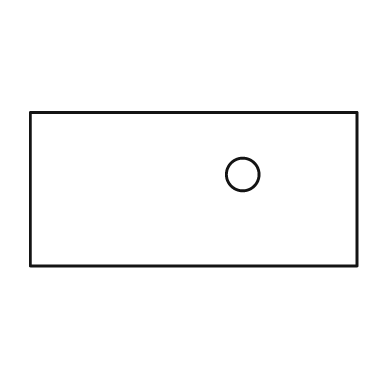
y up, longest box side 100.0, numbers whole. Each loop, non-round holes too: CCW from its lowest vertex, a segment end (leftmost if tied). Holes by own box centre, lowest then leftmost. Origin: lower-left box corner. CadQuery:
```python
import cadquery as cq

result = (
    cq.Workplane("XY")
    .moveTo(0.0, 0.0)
    .lineTo(100.0, 0.0)
    .lineTo(100.0, 47.0)
    .lineTo(0.0, 47.0)
    .close()
    .moveTo(65.0, 28.0)
    .circle(5.0)
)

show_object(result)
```